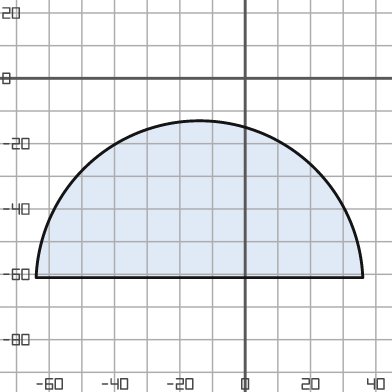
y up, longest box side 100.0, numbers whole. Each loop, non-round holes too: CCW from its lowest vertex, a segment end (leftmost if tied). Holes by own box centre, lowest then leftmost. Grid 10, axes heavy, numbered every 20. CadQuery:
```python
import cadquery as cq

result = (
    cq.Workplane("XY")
    .moveTo(-64.0, -61.0)
    .lineTo(36.0, -61.0)
    .threePointArc((-14.0, -13.0), (-64.0, -61.0))
    .close()
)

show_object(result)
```